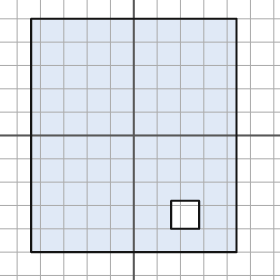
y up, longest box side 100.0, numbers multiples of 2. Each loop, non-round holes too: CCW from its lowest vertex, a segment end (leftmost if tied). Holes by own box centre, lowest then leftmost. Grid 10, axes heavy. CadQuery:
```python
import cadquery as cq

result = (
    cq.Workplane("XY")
    .moveTo(-44.0, -50.0)
    .lineTo(44.0, -50.0)
    .lineTo(44.0, 50.0)
    .lineTo(-44.0, 50.0)
    .close()
    .moveTo(16.0, -40.0)
    .lineTo(28.0, -40.0)
    .lineTo(28.0, -28.0)
    .lineTo(16.0, -28.0)
    .close()
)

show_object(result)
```